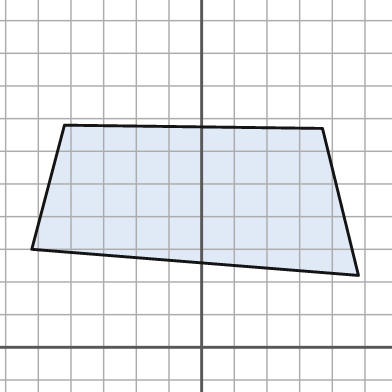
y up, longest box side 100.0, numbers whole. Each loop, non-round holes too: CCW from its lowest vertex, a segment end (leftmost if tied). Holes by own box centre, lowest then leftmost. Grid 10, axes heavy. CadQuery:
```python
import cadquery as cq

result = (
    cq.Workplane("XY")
    .moveTo(48.0, 22.0)
    .lineTo(37.0, 67.0)
    .lineTo(-42.0, 68.0)
    .lineTo(-52.0, 30.0)
    .close()
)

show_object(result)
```